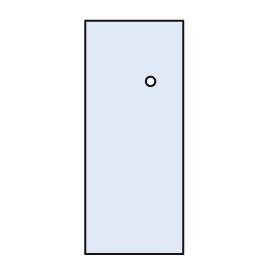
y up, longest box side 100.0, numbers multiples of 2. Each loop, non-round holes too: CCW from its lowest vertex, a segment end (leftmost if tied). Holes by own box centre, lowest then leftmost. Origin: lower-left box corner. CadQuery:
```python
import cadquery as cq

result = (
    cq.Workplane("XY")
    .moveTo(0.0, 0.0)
    .lineTo(42.0, 0.0)
    .lineTo(42.0, 100.0)
    .lineTo(0.0, 100.0)
    .close()
    .moveTo(28.0, 74.0)
    .circle(2.0)
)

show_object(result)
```